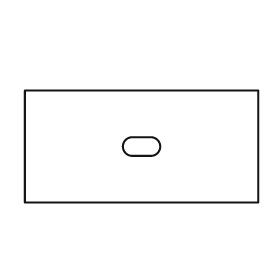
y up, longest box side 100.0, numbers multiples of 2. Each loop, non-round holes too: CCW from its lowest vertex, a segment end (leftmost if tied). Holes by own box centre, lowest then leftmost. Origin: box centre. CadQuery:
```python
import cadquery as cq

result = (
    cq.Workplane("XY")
    .moveTo(-50.0, -24.0)
    .lineTo(50.0, -24.0)
    .lineTo(50.0, 24.0)
    .lineTo(-50.0, 24.0)
    .close()
    .moveTo(-4.0, -4.0)
    .lineTo(4.0, -4.0)
    .threePointArc((8.0, 0.0), (4.0, 4.0))
    .lineTo(-4.0, 4.0)
    .threePointArc((-8.0, 0.0), (-4.0, -4.0))
    .close()
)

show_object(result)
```